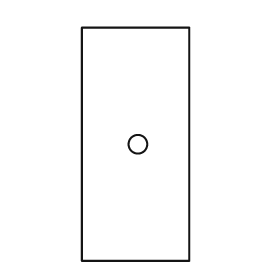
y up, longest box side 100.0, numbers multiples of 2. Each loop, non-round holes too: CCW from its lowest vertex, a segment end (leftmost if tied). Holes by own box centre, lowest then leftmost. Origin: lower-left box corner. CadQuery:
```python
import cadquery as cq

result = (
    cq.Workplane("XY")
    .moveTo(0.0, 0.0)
    .lineTo(46.0, 0.0)
    .lineTo(46.0, 100.0)
    .lineTo(0.0, 100.0)
    .close()
    .moveTo(24.0, 50.0)
    .circle(4.0)
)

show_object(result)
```